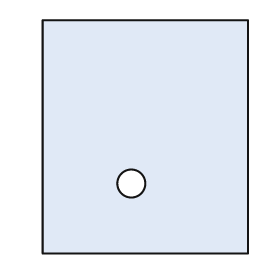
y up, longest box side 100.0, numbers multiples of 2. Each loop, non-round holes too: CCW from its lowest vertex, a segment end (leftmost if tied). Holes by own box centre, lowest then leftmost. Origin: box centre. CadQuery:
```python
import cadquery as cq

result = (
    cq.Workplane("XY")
    .moveTo(-44.0, -50.0)
    .lineTo(44.0, -50.0)
    .lineTo(44.0, 50.0)
    .lineTo(-44.0, 50.0)
    .close()
    .moveTo(-6.0, -20.0)
    .circle(6.0)
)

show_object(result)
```